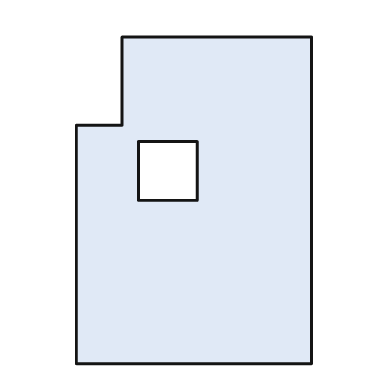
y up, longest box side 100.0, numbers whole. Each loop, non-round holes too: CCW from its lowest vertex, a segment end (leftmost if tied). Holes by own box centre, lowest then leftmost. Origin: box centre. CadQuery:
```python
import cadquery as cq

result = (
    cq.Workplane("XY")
    .moveTo(-36.0, -50.0)
    .lineTo(36.0, -50.0)
    .lineTo(36.0, 50.0)
    .lineTo(-22.0, 50.0)
    .lineTo(-22.0, 23.0)
    .lineTo(-36.0, 23.0)
    .close()
    .moveTo(-17.0, 0.0)
    .lineTo(1.0, 0.0)
    .lineTo(1.0, 18.0)
    .lineTo(-17.0, 18.0)
    .close()
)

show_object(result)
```